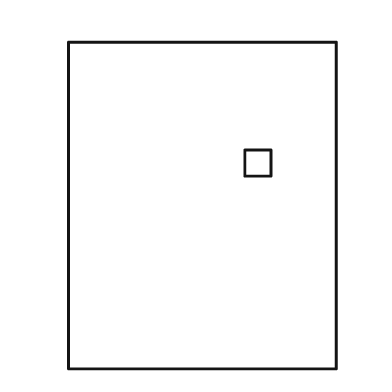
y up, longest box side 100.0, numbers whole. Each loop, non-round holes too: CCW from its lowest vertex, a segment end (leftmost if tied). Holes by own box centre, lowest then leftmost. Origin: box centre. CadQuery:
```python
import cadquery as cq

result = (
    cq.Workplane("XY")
    .moveTo(-41.0, -50.0)
    .lineTo(41.0, -50.0)
    .lineTo(41.0, 50.0)
    .lineTo(-41.0, 50.0)
    .close()
    .moveTo(13.0, 9.0)
    .lineTo(21.0, 9.0)
    .lineTo(21.0, 17.0)
    .lineTo(13.0, 17.0)
    .close()
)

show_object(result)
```